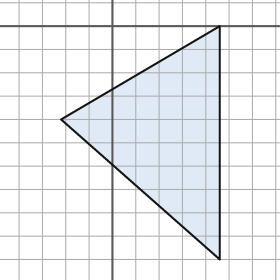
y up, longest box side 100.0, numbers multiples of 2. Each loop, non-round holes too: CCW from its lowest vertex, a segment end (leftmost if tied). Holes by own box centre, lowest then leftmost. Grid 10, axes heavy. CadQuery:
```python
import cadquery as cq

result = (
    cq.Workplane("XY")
    .moveTo(46.0, -100.0)
    .lineTo(46.0, 0.0)
    .lineTo(-22.0, -40.0)
    .close()
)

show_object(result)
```